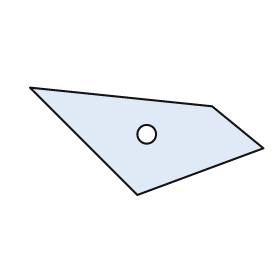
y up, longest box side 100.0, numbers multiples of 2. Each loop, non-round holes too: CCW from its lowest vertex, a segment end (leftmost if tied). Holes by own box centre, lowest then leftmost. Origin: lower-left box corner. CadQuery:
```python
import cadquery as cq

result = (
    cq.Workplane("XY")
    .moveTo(46.0, 0.0)
    .lineTo(100.0, 20.0)
    .lineTo(78.0, 38.0)
    .lineTo(0.0, 46.0)
    .close()
    .moveTo(50.0, 26.0)
    .circle(4.0)
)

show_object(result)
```